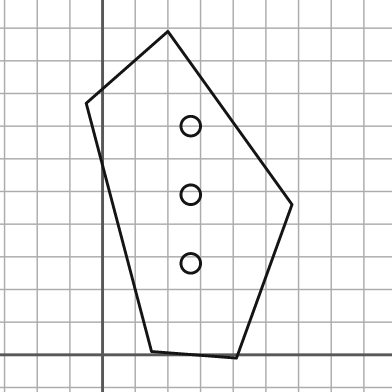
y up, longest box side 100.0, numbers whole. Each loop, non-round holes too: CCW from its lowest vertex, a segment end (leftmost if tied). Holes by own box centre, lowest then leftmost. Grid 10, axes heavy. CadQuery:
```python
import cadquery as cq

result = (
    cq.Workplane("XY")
    .moveTo(41.0, -1.0)
    .lineTo(58.0, 46.0)
    .lineTo(20.0, 99.0)
    .lineTo(-5.0, 77.0)
    .lineTo(15.0, 1.0)
    .close()
    .moveTo(27.0, 28.0)
    .circle(3.0)
    .moveTo(27.0, 49.0)
    .circle(3.0)
    .moveTo(27.0, 70.0)
    .circle(3.0)
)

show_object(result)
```